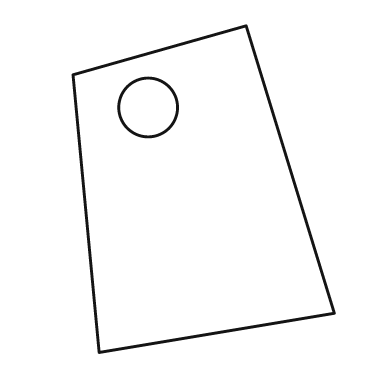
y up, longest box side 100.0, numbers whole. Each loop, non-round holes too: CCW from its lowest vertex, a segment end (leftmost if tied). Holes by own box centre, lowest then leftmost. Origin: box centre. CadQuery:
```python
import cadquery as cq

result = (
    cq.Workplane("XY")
    .moveTo(-32.0, -50.0)
    .lineTo(40.0, -38.0)
    .lineTo(13.0, 50.0)
    .lineTo(-40.0, 35.0)
    .close()
    .moveTo(-17.0, 25.0)
    .circle(9.0)
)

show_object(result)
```